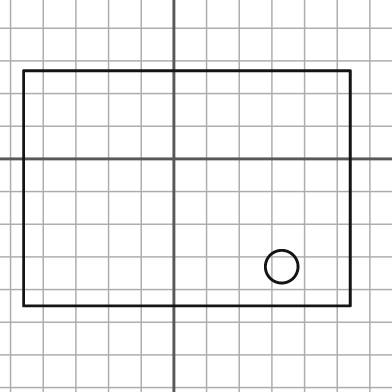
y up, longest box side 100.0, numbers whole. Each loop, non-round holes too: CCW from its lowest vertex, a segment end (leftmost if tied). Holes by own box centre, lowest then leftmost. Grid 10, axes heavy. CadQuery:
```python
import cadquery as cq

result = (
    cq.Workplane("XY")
    .moveTo(-46.0, -45.0)
    .lineTo(54.0, -45.0)
    .lineTo(54.0, 27.0)
    .lineTo(-46.0, 27.0)
    .close()
    .moveTo(33.0, -33.0)
    .circle(5.0)
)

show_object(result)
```